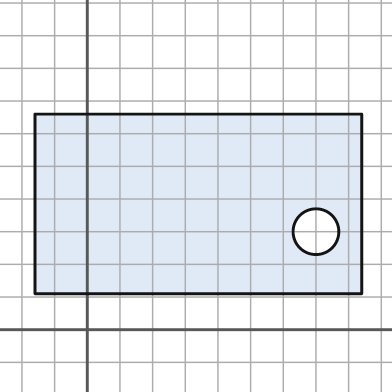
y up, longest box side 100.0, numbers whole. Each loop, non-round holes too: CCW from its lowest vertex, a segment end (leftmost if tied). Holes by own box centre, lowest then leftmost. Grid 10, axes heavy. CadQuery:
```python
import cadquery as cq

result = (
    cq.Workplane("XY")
    .moveTo(-16.0, 11.0)
    .lineTo(84.0, 11.0)
    .lineTo(84.0, 66.0)
    .lineTo(-16.0, 66.0)
    .close()
    .moveTo(70.0, 30.0)
    .circle(7.0)
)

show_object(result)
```